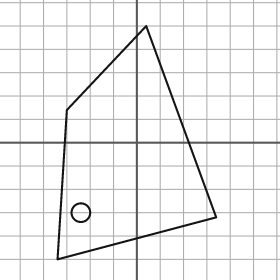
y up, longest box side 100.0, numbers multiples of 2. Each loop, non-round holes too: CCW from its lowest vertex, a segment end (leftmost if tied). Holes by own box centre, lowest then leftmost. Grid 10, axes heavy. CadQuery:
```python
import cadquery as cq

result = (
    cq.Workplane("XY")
    .moveTo(-34.0, -50.0)
    .lineTo(34.0, -32.0)
    .lineTo(4.0, 50.0)
    .lineTo(-30.0, 14.0)
    .close()
    .moveTo(-24.0, -30.0)
    .circle(4.0)
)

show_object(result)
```